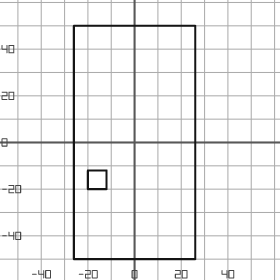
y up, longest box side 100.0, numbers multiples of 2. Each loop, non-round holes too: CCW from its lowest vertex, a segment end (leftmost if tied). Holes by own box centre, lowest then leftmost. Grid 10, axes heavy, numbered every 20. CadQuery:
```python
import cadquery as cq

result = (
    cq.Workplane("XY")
    .moveTo(-26.0, -50.0)
    .lineTo(26.0, -50.0)
    .lineTo(26.0, 50.0)
    .lineTo(-26.0, 50.0)
    .close()
    .moveTo(-20.0, -20.0)
    .lineTo(-12.0, -20.0)
    .lineTo(-12.0, -12.0)
    .lineTo(-20.0, -12.0)
    .close()
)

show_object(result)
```